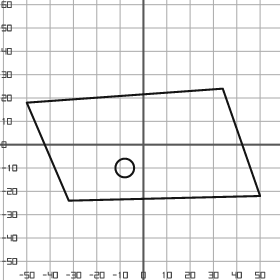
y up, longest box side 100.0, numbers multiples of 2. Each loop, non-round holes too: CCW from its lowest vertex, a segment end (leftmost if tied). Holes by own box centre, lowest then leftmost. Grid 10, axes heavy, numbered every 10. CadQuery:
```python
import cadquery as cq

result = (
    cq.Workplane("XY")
    .moveTo(-32.0, -24.0)
    .lineTo(50.0, -22.0)
    .lineTo(34.0, 24.0)
    .lineTo(-50.0, 18.0)
    .close()
    .moveTo(-8.0, -10.0)
    .circle(4.0)
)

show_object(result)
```